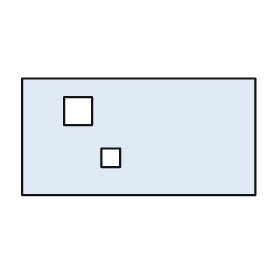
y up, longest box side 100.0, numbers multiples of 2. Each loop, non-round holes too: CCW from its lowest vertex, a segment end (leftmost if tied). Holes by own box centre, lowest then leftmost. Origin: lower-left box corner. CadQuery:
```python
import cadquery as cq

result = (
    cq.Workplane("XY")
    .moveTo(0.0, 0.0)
    .lineTo(100.0, 0.0)
    .lineTo(100.0, 50.0)
    .lineTo(0.0, 50.0)
    .close()
    .moveTo(34.0, 12.0)
    .lineTo(42.0, 12.0)
    .lineTo(42.0, 20.0)
    .lineTo(34.0, 20.0)
    .close()
    .moveTo(18.0, 30.0)
    .lineTo(30.0, 30.0)
    .lineTo(30.0, 42.0)
    .lineTo(18.0, 42.0)
    .close()
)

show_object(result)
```